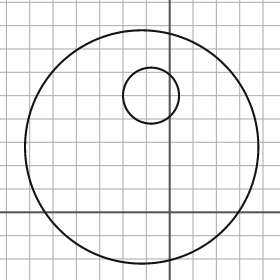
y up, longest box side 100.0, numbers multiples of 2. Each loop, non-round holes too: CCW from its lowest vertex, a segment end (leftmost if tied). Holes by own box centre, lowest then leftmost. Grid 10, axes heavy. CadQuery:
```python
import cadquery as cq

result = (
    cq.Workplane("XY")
    .moveTo(-12.0, 28.0)
    .circle(50.0)
    .moveTo(-8.0, 50.0)
    .circle(12.0)
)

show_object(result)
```